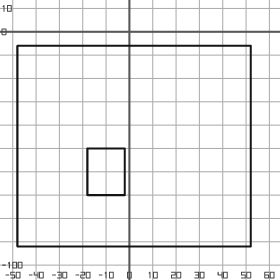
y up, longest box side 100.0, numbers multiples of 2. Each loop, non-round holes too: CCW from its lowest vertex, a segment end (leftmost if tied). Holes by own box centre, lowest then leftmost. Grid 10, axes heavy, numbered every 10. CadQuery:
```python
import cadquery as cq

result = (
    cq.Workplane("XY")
    .moveTo(-48.0, -92.0)
    .lineTo(52.0, -92.0)
    .lineTo(52.0, -6.0)
    .lineTo(-48.0, -6.0)
    .close()
    .moveTo(-18.0, -70.0)
    .lineTo(-2.0, -70.0)
    .lineTo(-2.0, -50.0)
    .lineTo(-18.0, -50.0)
    .close()
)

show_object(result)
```